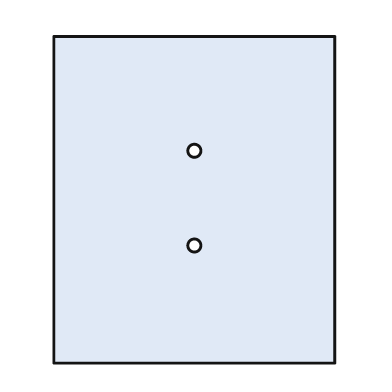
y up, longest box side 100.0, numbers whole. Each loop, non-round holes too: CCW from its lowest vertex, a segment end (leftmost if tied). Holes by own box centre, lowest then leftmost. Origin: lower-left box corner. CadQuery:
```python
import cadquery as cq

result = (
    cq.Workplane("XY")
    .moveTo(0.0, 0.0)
    .lineTo(86.0, 0.0)
    .lineTo(86.0, 100.0)
    .lineTo(0.0, 100.0)
    .close()
    .moveTo(43.0, 36.0)
    .circle(2.0)
    .moveTo(43.0, 65.0)
    .circle(2.0)
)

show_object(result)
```